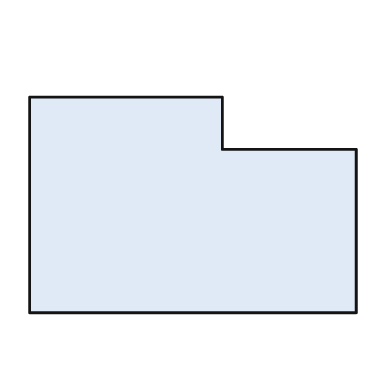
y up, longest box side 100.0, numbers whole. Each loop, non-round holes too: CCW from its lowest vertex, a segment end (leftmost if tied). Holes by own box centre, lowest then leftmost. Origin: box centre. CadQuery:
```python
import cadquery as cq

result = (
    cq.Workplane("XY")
    .moveTo(-50.0, -33.0)
    .lineTo(50.0, -33.0)
    .lineTo(50.0, 17.0)
    .lineTo(9.0, 17.0)
    .lineTo(9.0, 33.0)
    .lineTo(-50.0, 33.0)
    .close()
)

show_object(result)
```